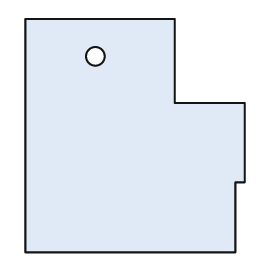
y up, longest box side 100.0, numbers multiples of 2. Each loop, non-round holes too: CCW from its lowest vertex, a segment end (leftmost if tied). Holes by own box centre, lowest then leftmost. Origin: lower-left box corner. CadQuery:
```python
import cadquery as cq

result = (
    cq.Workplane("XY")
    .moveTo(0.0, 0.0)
    .lineTo(90.0, 0.0)
    .lineTo(90.0, 30.0)
    .lineTo(94.0, 30.0)
    .lineTo(94.0, 64.0)
    .lineTo(64.0, 64.0)
    .lineTo(64.0, 100.0)
    .lineTo(0.0, 100.0)
    .close()
    .moveTo(30.0, 84.0)
    .circle(4.0)
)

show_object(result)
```